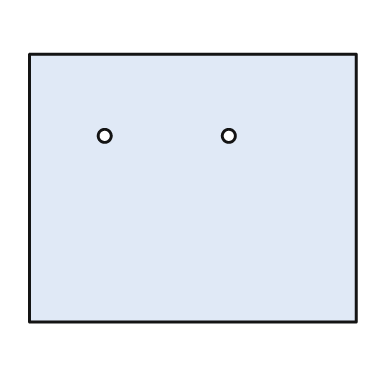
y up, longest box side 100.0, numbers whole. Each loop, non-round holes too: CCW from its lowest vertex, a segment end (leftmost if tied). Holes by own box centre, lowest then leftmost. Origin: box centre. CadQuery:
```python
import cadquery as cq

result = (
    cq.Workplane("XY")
    .moveTo(-50.0, -41.0)
    .lineTo(50.0, -41.0)
    .lineTo(50.0, 41.0)
    .lineTo(-50.0, 41.0)
    .close()
    .moveTo(-27.0, 16.0)
    .circle(2.0)
    .moveTo(11.0, 16.0)
    .circle(2.0)
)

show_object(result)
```